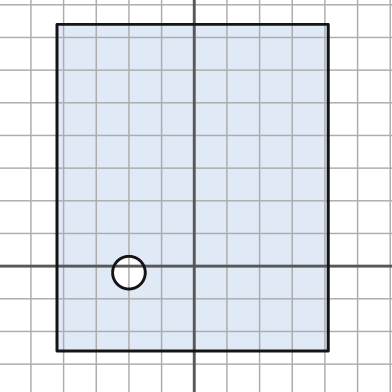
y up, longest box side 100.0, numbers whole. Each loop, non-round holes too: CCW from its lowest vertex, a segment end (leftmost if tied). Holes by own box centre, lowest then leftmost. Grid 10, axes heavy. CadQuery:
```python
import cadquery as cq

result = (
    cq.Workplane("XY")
    .moveTo(-42.0, -26.0)
    .lineTo(41.0, -26.0)
    .lineTo(41.0, 74.0)
    .lineTo(-42.0, 74.0)
    .close()
    .moveTo(-20.0, -2.0)
    .circle(5.0)
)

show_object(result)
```